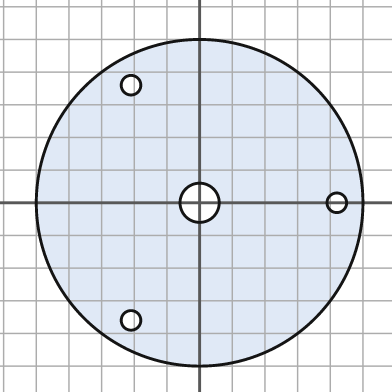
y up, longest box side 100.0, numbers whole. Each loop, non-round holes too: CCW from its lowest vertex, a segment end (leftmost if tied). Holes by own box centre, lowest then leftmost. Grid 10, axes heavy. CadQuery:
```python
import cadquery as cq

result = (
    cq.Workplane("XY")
    .moveTo(0.0, 0.0)
    .circle(50.0)
    .moveTo(-21.0, -36.0)
    .circle(3.0)
    .moveTo(0.0, 0.0)
    .circle(6.0)
    .moveTo(42.0, 0.0)
    .circle(3.0)
    .moveTo(-21.0, 36.0)
    .circle(3.0)
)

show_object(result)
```